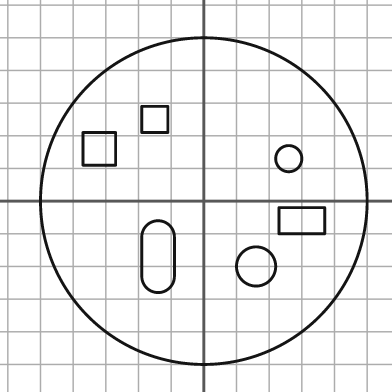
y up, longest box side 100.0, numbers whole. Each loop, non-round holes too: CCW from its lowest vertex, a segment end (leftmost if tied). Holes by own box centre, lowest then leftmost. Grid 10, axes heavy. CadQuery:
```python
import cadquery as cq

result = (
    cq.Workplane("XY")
    .moveTo(0.0, 0.0)
    .circle(50.0)
    .moveTo(16.0, -20.0)
    .circle(6.0)
    .moveTo(-19.0, -23.0)
    .threePointArc((-14.0, -28.0), (-9.0, -23.0))
    .lineTo(-9.0, -11.0)
    .threePointArc((-14.0, -6.0), (-19.0, -11.0))
    .close()
    .moveTo(23.0, -10.0)
    .lineTo(37.0, -10.0)
    .lineTo(37.0, -2.0)
    .lineTo(23.0, -2.0)
    .close()
    .moveTo(26.0, 13.0)
    .circle(4.0)
    .moveTo(-37.0, 11.0)
    .lineTo(-27.0, 11.0)
    .lineTo(-27.0, 21.0)
    .lineTo(-37.0, 21.0)
    .close()
    .moveTo(-19.0, 21.0)
    .lineTo(-11.0, 21.0)
    .lineTo(-11.0, 29.0)
    .lineTo(-19.0, 29.0)
    .close()
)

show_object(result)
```